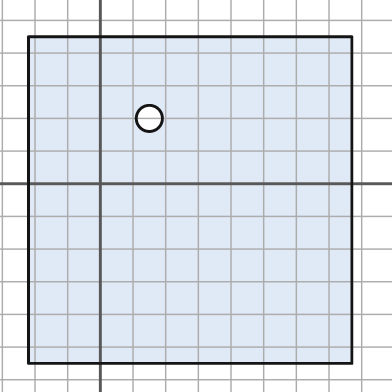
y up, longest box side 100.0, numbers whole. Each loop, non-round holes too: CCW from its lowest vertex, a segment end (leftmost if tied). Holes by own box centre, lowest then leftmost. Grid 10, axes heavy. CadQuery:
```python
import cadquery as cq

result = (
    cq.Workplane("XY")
    .moveTo(-22.0, -55.0)
    .lineTo(77.0, -55.0)
    .lineTo(77.0, 45.0)
    .lineTo(-22.0, 45.0)
    .close()
    .moveTo(15.0, 20.0)
    .circle(4.0)
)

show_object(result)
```